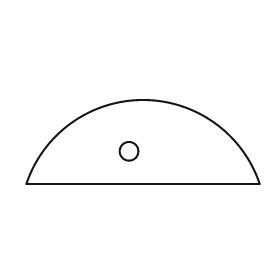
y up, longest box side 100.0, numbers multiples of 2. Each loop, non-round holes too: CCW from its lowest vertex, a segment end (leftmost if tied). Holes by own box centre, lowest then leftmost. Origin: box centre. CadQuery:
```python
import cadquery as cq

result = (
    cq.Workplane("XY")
    .moveTo(-50.0, -18.0)
    .lineTo(50.0, -18.0)
    .threePointArc((0.0, 18.0), (-50.0, -18.0))
    .close()
    .moveTo(-6.0, -4.0)
    .circle(4.0)
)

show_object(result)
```